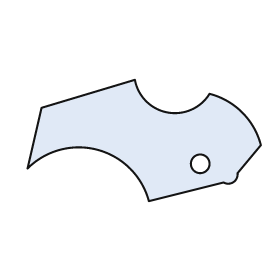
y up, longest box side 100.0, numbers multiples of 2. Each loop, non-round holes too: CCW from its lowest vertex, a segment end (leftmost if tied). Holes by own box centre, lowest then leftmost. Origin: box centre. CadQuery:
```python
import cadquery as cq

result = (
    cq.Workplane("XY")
    .moveTo(2.0, -26.0)
    .lineTo(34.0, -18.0)
    .threePointArc((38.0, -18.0), (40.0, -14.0))
    .lineTo(50.0, -2.0)
    .threePointArc((42.0, 12.0), (28.0, 20.0))
    .threePointArc((10.0, 12.0), (-4.0, 26.0))
    .lineTo(-44.0, 14.0)
    .lineTo(-50.0, -12.0)
    .threePointArc((-20.0, -4.0), (2.0, -26.0))
    .close()
    .moveTo(24.0, -10.0)
    .circle(4.0)
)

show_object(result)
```